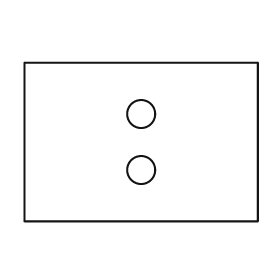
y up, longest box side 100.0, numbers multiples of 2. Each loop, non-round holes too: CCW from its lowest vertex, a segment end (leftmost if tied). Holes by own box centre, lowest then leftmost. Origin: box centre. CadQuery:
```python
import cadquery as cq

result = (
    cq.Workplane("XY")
    .moveTo(-50.0, -34.0)
    .lineTo(50.0, -34.0)
    .lineTo(50.0, 34.0)
    .lineTo(-50.0, 34.0)
    .close()
    .moveTo(0.0, -12.0)
    .circle(6.0)
    .moveTo(0.0, 12.0)
    .circle(6.0)
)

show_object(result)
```